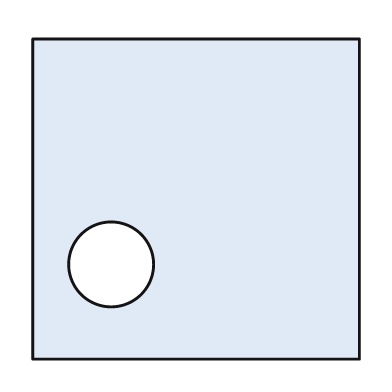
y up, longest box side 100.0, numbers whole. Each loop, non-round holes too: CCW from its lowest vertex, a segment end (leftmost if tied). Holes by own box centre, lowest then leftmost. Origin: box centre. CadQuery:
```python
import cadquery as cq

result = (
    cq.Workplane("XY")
    .moveTo(-50.0, -49.0)
    .lineTo(50.0, -49.0)
    .lineTo(50.0, 49.0)
    .lineTo(-50.0, 49.0)
    .close()
    .moveTo(-26.0, -20.0)
    .circle(13.0)
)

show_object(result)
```